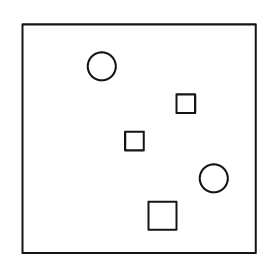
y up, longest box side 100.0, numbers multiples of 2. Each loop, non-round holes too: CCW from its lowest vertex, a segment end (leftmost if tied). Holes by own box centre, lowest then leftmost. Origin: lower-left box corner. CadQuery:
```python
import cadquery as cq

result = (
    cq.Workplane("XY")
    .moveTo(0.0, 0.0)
    .lineTo(100.0, 0.0)
    .lineTo(100.0, 98.0)
    .lineTo(0.0, 98.0)
    .close()
    .moveTo(54.0, 10.0)
    .lineTo(66.0, 10.0)
    .lineTo(66.0, 22.0)
    .lineTo(54.0, 22.0)
    .close()
    .moveTo(82.0, 32.0)
    .circle(6.0)
    .moveTo(44.0, 44.0)
    .lineTo(52.0, 44.0)
    .lineTo(52.0, 52.0)
    .lineTo(44.0, 52.0)
    .close()
    .moveTo(66.0, 60.0)
    .lineTo(74.0, 60.0)
    .lineTo(74.0, 68.0)
    .lineTo(66.0, 68.0)
    .close()
    .moveTo(34.0, 80.0)
    .circle(6.0)
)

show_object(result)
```